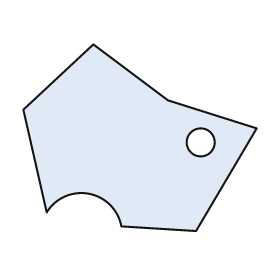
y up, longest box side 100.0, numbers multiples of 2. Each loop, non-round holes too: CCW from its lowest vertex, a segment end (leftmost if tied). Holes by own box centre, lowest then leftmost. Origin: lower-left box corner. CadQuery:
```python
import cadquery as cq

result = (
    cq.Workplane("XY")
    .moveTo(74.0, 0.0)
    .lineTo(100.0, 44.0)
    .lineTo(62.0, 56.0)
    .lineTo(30.0, 80.0)
    .lineTo(0.0, 52.0)
    .lineTo(10.0, 8.0)
    .threePointArc((28.0, 16.0), (42.0, 2.0))
    .close()
    .moveTo(76.0, 38.0)
    .circle(6.0)
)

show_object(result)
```